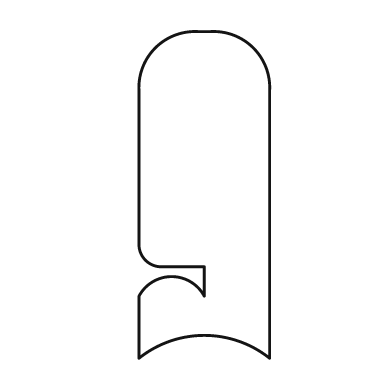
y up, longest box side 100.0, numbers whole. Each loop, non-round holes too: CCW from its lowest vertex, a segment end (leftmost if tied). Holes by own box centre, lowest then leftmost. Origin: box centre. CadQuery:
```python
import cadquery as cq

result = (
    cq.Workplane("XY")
    .moveTo(-20.0, -50.0)
    .threePointArc((0.0, -43.0), (20.0, -50.0))
    .lineTo(20.0, 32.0)
    .threePointArc((15.0, 45.0), (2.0, 50.0))
    .lineTo(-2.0, 50.0)
    .threePointArc((-15.0, 45.0), (-20.0, 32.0))
    .lineTo(-20.0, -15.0)
    .threePointArc((-18.0, -20.0), (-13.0, -22.0))
    .lineTo(0.0, -22.0)
    .lineTo(0.0, -31.0)
    .threePointArc((-10.0, -25.0), (-20.0, -31.0))
    .close()
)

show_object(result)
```